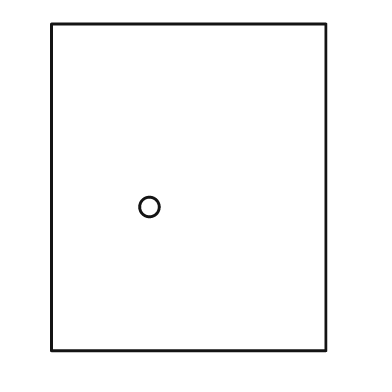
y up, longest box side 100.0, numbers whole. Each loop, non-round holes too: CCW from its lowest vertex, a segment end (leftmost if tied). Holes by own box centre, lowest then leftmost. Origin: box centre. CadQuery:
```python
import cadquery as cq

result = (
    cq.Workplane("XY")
    .moveTo(-42.0, -50.0)
    .lineTo(42.0, -50.0)
    .lineTo(42.0, 50.0)
    .lineTo(-42.0, 50.0)
    .close()
    .moveTo(-12.0, -6.0)
    .circle(3.0)
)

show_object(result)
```